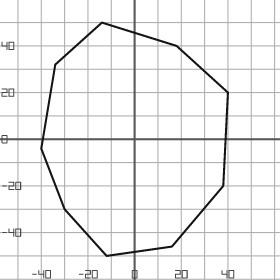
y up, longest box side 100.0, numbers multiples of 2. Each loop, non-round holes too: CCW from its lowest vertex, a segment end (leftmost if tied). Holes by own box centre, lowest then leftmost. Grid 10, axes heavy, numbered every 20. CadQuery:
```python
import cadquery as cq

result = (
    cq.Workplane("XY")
    .moveTo(-12.0, -50.0)
    .lineTo(16.0, -46.0)
    .lineTo(38.0, -20.0)
    .lineTo(40.0, 20.0)
    .lineTo(18.0, 40.0)
    .lineTo(-14.0, 50.0)
    .lineTo(-34.0, 32.0)
    .lineTo(-40.0, -4.0)
    .lineTo(-30.0, -30.0)
    .close()
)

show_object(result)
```